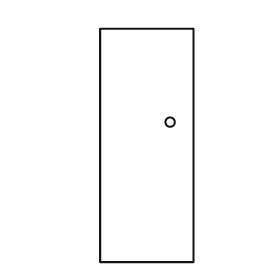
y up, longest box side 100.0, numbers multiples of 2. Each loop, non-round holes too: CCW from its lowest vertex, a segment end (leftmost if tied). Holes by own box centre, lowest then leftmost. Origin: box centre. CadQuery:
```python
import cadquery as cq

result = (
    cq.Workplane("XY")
    .moveTo(-20.0, -50.0)
    .lineTo(20.0, -50.0)
    .lineTo(20.0, 50.0)
    .lineTo(-20.0, 50.0)
    .close()
    .moveTo(10.0, 10.0)
    .circle(2.0)
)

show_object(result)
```